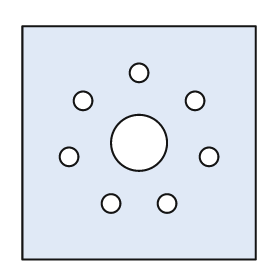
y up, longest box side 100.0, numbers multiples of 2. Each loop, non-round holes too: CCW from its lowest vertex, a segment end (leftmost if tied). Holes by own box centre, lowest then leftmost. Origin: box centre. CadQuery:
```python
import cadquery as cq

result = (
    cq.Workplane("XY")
    .moveTo(-50.0, -50.0)
    .lineTo(50.0, -50.0)
    .lineTo(50.0, 50.0)
    .lineTo(-50.0, 50.0)
    .close()
    .moveTo(-12.0, -26.0)
    .circle(4.0)
    .moveTo(12.0, -26.0)
    .circle(4.0)
    .moveTo(-30.0, -6.0)
    .circle(4.0)
    .moveTo(30.0, -6.0)
    .circle(4.0)
    .moveTo(0.0, 0.0)
    .circle(12.0)
    .moveTo(-24.0, 18.0)
    .circle(4.0)
    .moveTo(24.0, 18.0)
    .circle(4.0)
    .moveTo(0.0, 30.0)
    .circle(4.0)
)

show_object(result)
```